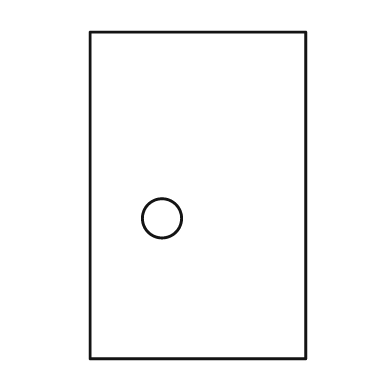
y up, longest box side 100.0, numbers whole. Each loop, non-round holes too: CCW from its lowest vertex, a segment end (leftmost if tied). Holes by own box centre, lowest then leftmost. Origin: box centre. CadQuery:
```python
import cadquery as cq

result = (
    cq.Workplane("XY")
    .moveTo(-33.0, -50.0)
    .lineTo(33.0, -50.0)
    .lineTo(33.0, 50.0)
    .lineTo(-33.0, 50.0)
    .close()
    .moveTo(-11.0, -7.0)
    .circle(6.0)
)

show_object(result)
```